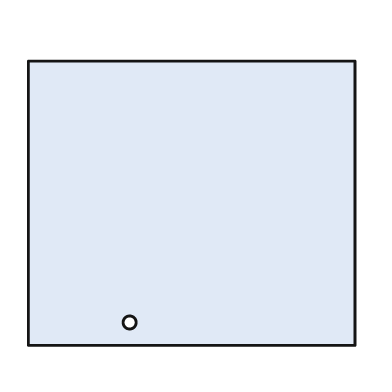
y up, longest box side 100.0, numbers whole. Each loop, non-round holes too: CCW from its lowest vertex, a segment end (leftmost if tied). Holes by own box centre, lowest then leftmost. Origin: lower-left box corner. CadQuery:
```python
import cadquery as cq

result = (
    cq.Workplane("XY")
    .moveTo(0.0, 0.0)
    .lineTo(100.0, 0.0)
    .lineTo(100.0, 87.0)
    .lineTo(0.0, 87.0)
    .close()
    .moveTo(31.0, 7.0)
    .circle(2.0)
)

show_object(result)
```